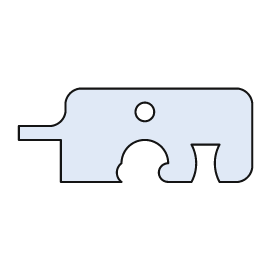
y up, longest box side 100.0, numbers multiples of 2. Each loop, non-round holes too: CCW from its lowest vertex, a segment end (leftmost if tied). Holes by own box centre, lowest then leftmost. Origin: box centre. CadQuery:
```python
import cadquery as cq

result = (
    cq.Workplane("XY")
    .moveTo(-32.0, -20.0)
    .lineTo(-6.0, -20.0)
    .threePointArc((-8.0, -16.0), (-6.0, -12.0))
    .threePointArc((4.0, -2.0), (14.0, -12.0))
    .threePointArc((10.0, -16.0), (14.0, -20.0))
    .lineTo(24.0, -20.0)
    .threePointArc((26.0, -12.0), (24.0, -4.0))
    .lineTo(36.0, -4.0)
    .threePointArc((34.0, -12.0), (36.0, -20.0))
    .lineTo(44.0, -20.0)
    .threePointArc((48.0, -18.0), (50.0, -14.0))
    .lineTo(50.0, 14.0)
    .threePointArc((48.0, 18.0), (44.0, 20.0))
    .lineTo(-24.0, 20.0)
    .threePointArc((-28.0, 18.0), (-30.0, 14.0))
    .lineTo(-30.0, 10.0)
    .threePointArc((-32.0, 6.0), (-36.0, 4.0))
    .lineTo(-50.0, 4.0)
    .lineTo(-50.0, -2.0)
    .lineTo(-32.0, -2.0)
    .close()
    .moveTo(4.0, 10.0)
    .circle(4.0)
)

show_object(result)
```